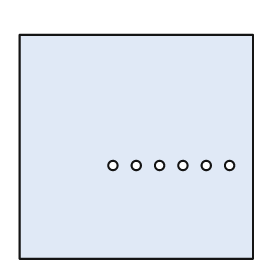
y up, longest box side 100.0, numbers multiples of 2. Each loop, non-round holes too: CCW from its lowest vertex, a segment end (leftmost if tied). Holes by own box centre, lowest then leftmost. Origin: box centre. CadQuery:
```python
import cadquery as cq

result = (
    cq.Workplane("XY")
    .moveTo(-50.0, -48.0)
    .lineTo(50.0, -48.0)
    .lineTo(50.0, 48.0)
    .lineTo(-50.0, 48.0)
    .close()
    .moveTo(-10.0, -8.0)
    .circle(2.0)
    .moveTo(0.0, -8.0)
    .circle(2.0)
    .moveTo(10.0, -8.0)
    .circle(2.0)
    .moveTo(20.0, -8.0)
    .circle(2.0)
    .moveTo(30.0, -8.0)
    .circle(2.0)
    .moveTo(40.0, -8.0)
    .circle(2.0)
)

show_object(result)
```